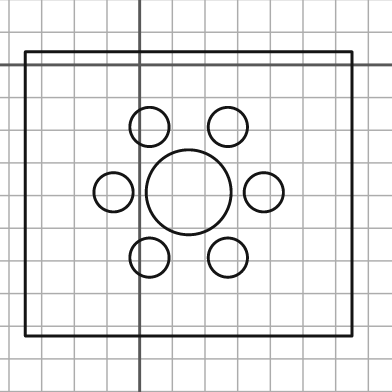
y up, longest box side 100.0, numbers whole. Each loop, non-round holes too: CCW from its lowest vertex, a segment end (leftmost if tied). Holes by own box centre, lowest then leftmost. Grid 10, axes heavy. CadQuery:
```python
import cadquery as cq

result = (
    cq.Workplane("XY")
    .moveTo(-35.0, -83.0)
    .lineTo(65.0, -83.0)
    .lineTo(65.0, 4.0)
    .lineTo(-35.0, 4.0)
    .close()
    .moveTo(3.0, -59.0)
    .circle(6.0)
    .moveTo(27.0, -59.0)
    .circle(6.0)
    .moveTo(-8.0, -39.0)
    .circle(6.0)
    .moveTo(15.0, -39.0)
    .circle(13.0)
    .moveTo(38.0, -39.0)
    .circle(6.0)
    .moveTo(3.0, -19.0)
    .circle(6.0)
    .moveTo(27.0, -19.0)
    .circle(6.0)
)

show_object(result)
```